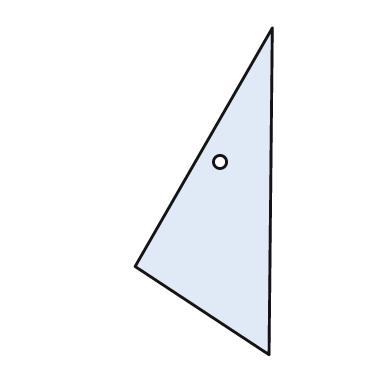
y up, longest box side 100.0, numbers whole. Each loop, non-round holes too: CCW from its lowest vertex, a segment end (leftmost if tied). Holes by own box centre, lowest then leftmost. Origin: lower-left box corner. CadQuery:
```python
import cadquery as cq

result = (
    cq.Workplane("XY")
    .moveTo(41.0, 0.0)
    .lineTo(42.0, 100.0)
    .lineTo(0.0, 27.0)
    .close()
    .moveTo(26.0, 59.0)
    .circle(2.0)
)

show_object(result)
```